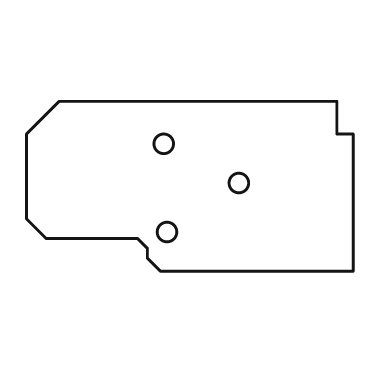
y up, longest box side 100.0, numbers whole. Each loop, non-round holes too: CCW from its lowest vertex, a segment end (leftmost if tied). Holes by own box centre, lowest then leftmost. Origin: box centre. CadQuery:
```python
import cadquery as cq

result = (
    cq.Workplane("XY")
    .moveTo(-9.0, -26.0)
    .lineTo(50.0, -26.0)
    .lineTo(50.0, 16.0)
    .lineTo(45.0, 16.0)
    .lineTo(45.0, 26.0)
    .lineTo(-40.0, 26.0)
    .lineTo(-50.0, 16.0)
    .lineTo(-50.0, -10.0)
    .lineTo(-44.0, -16.0)
    .lineTo(-16.0, -16.0)
    .lineTo(-13.0, -19.0)
    .lineTo(-13.0, -22.0)
    .close()
    .moveTo(-7.0, -14.0)
    .circle(3.0)
    .moveTo(15.0, 1.0)
    .circle(3.0)
    .moveTo(-8.0, 13.0)
    .circle(3.0)
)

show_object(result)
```